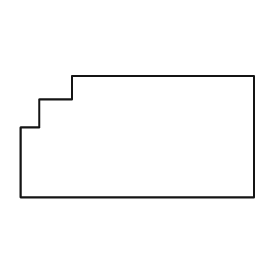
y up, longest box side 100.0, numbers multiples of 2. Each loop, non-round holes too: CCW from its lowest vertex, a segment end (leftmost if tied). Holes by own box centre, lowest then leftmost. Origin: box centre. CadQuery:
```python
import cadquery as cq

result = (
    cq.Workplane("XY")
    .moveTo(-50.0, -26.0)
    .lineTo(50.0, -26.0)
    .lineTo(50.0, 26.0)
    .lineTo(-28.0, 26.0)
    .lineTo(-28.0, 16.0)
    .lineTo(-42.0, 16.0)
    .lineTo(-42.0, 4.0)
    .lineTo(-50.0, 4.0)
    .close()
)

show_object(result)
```